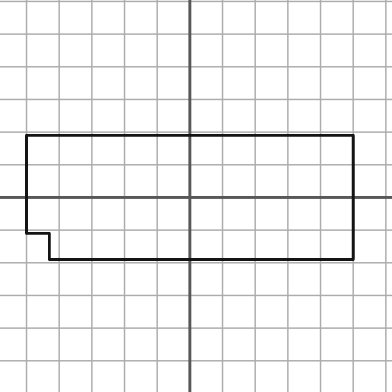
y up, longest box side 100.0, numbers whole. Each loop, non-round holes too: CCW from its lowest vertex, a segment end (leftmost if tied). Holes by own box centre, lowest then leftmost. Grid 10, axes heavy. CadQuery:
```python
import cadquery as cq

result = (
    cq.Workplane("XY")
    .moveTo(-43.0, -19.0)
    .lineTo(50.0, -19.0)
    .lineTo(50.0, 19.0)
    .lineTo(-50.0, 19.0)
    .lineTo(-50.0, -11.0)
    .lineTo(-43.0, -11.0)
    .close()
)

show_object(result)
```